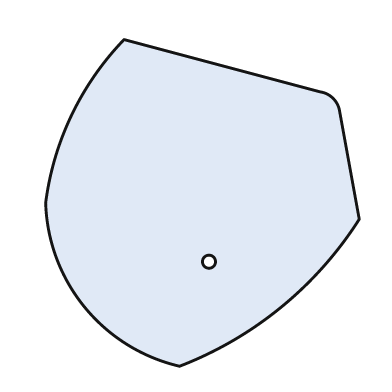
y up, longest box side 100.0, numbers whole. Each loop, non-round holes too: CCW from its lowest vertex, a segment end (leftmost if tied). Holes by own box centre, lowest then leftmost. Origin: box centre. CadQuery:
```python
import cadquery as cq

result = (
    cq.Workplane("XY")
    .moveTo(-7.0, -50.0)
    .threePointArc((24.0, -32.0), (48.0, -5.0))
    .lineTo(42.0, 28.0)
    .threePointArc((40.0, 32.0), (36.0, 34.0))
    .lineTo(-24.0, 50.0)
    .threePointArc((-40.0, 27.0), (-48.0, 0.0))
    .threePointArc((-36.0, -32.0), (-7.0, -50.0))
    .close()
    .moveTo(2.0, -18.0)
    .circle(2.0)
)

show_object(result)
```